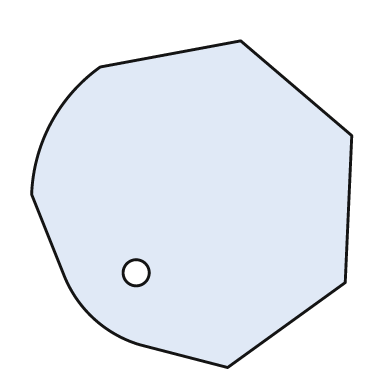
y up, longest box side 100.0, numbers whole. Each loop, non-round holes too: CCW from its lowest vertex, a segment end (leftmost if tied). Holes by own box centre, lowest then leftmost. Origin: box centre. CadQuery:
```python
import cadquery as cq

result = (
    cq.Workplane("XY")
    .moveTo(11.0, -50.0)
    .lineTo(47.0, -24.0)
    .lineTo(49.0, 21.0)
    .lineTo(15.0, 50.0)
    .lineTo(-28.0, 42.0)
    .threePointArc((-43.0, 25.0), (-49.0, 3.0))
    .lineTo(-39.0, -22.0)
    .threePointArc((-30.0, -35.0), (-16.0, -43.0))
    .close()
    .moveTo(-17.0, -21.0)
    .circle(4.0)
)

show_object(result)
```